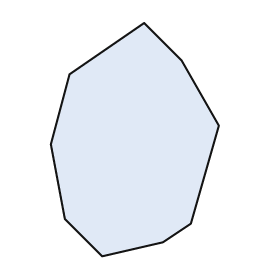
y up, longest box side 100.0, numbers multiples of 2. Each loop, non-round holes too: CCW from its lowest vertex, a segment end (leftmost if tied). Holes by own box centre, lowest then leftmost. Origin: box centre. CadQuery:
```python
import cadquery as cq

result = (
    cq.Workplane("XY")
    .moveTo(-14.0, -50.0)
    .lineTo(12.0, -44.0)
    .lineTo(24.0, -36.0)
    .lineTo(36.0, 6.0)
    .lineTo(20.0, 34.0)
    .lineTo(4.0, 50.0)
    .lineTo(-28.0, 28.0)
    .lineTo(-36.0, -2.0)
    .lineTo(-30.0, -34.0)
    .close()
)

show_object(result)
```